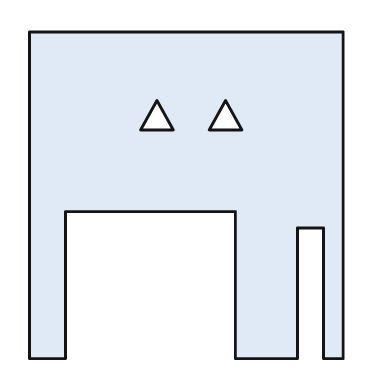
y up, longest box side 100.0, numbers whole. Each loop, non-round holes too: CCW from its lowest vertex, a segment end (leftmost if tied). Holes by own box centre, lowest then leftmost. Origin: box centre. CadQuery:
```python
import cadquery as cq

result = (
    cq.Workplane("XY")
    .moveTo(-48.0, -50.0)
    .lineTo(-37.0, -50.0)
    .lineTo(-37.0, -5.0)
    .lineTo(15.0, -5.0)
    .lineTo(15.0, -50.0)
    .lineTo(34.0, -50.0)
    .lineTo(34.0, -10.0)
    .lineTo(42.0, -10.0)
    .lineTo(42.0, -50.0)
    .lineTo(48.0, -50.0)
    .lineTo(48.0, 50.0)
    .lineTo(-48.0, 50.0)
    .close()
    .moveTo(-14.0, 20.0)
    .lineTo(-4.0, 20.0)
    .lineTo(-9.0, 29.0)
    .close()
    .moveTo(7.0, 20.0)
    .lineTo(17.0, 20.0)
    .lineTo(12.0, 29.0)
    .close()
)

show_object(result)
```